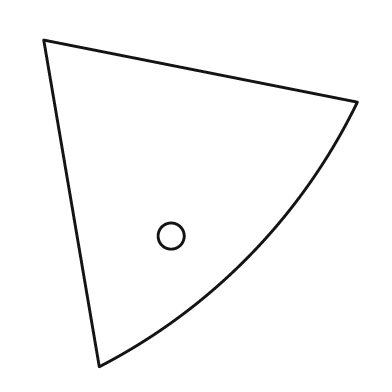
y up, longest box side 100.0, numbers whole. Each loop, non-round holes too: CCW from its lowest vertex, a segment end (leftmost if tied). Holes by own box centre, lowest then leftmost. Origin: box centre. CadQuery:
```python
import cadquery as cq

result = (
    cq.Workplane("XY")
    .moveTo(-31.0, -50.0)
    .threePointArc((15.0, -16.0), (48.0, 31.0))
    .lineTo(-48.0, 50.0)
    .close()
    .moveTo(-9.0, -10.0)
    .circle(4.0)
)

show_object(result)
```